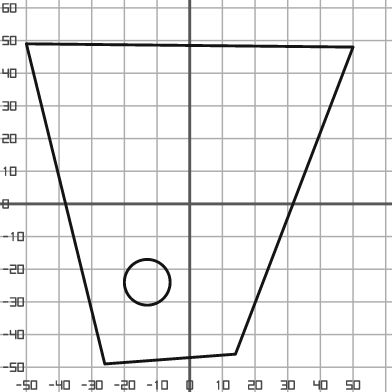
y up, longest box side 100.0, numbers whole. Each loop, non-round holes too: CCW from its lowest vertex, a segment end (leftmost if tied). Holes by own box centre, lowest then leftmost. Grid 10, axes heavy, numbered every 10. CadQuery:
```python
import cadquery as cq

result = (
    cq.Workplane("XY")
    .moveTo(-26.0, -49.0)
    .lineTo(14.0, -46.0)
    .lineTo(50.0, 48.0)
    .lineTo(-50.0, 49.0)
    .close()
    .moveTo(-13.0, -24.0)
    .circle(7.0)
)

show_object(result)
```